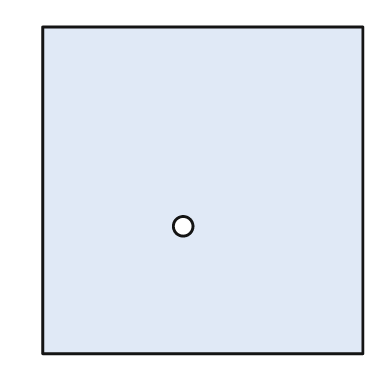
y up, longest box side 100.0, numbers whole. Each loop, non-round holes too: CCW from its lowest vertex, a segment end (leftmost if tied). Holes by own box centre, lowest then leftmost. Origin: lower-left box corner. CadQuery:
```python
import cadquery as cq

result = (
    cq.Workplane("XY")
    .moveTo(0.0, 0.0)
    .lineTo(98.0, 0.0)
    .lineTo(98.0, 100.0)
    .lineTo(0.0, 100.0)
    .close()
    .moveTo(43.0, 39.0)
    .circle(3.0)
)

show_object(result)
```